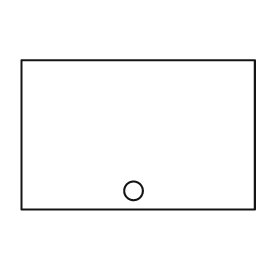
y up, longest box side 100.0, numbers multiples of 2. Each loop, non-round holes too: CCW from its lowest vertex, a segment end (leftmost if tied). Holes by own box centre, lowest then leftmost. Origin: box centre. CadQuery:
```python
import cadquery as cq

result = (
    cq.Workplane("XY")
    .moveTo(-50.0, -32.0)
    .lineTo(50.0, -32.0)
    .lineTo(50.0, 32.0)
    .lineTo(-50.0, 32.0)
    .close()
    .moveTo(-2.0, -24.0)
    .circle(4.0)
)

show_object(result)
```